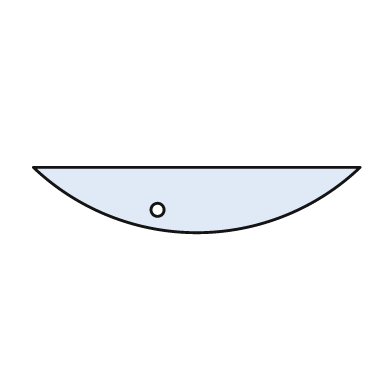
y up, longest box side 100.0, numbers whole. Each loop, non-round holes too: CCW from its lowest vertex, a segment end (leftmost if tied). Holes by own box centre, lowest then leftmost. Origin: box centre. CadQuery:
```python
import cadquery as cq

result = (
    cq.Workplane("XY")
    .moveTo(-50.0, 10.0)
    .threePointArc((0.0, -10.0), (50.0, 10.0))
    .close()
    .moveTo(-12.0, -3.0)
    .circle(2.0)
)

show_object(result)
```